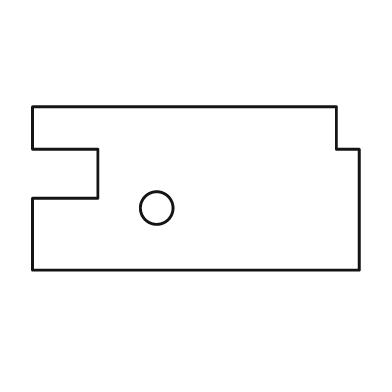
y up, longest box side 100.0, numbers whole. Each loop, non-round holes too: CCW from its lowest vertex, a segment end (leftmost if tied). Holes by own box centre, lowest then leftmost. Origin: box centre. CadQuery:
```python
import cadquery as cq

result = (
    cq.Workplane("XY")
    .moveTo(-50.0, -25.0)
    .lineTo(50.0, -25.0)
    .lineTo(50.0, 12.0)
    .lineTo(43.0, 12.0)
    .lineTo(43.0, 25.0)
    .lineTo(-50.0, 25.0)
    .lineTo(-50.0, 12.0)
    .lineTo(-30.0, 12.0)
    .lineTo(-30.0, -3.0)
    .lineTo(-50.0, -3.0)
    .close()
    .moveTo(-12.0, -6.0)
    .circle(5.0)
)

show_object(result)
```